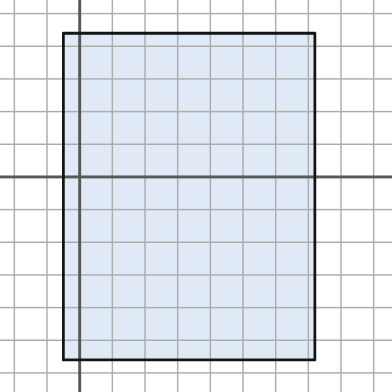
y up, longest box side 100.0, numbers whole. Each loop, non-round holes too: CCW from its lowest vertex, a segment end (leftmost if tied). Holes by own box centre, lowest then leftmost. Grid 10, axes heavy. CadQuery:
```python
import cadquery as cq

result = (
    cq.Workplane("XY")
    .moveTo(-5.0, -56.0)
    .lineTo(72.0, -56.0)
    .lineTo(72.0, 44.0)
    .lineTo(-5.0, 44.0)
    .close()
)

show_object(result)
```